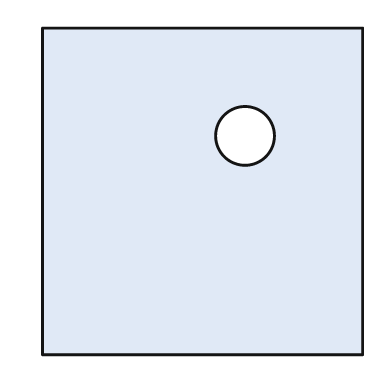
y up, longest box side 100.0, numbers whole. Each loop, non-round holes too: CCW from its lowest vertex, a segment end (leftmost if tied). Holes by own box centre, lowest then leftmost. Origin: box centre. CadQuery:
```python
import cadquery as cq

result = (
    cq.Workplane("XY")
    .moveTo(-49.0, -50.0)
    .lineTo(49.0, -50.0)
    .lineTo(49.0, 50.0)
    .lineTo(-49.0, 50.0)
    .close()
    .moveTo(13.0, 17.0)
    .circle(9.0)
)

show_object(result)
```